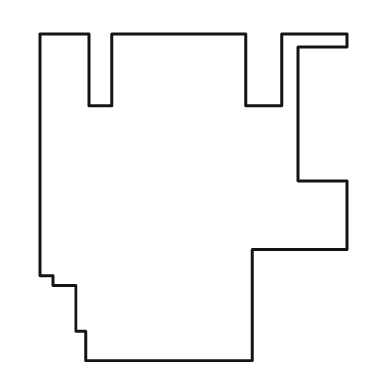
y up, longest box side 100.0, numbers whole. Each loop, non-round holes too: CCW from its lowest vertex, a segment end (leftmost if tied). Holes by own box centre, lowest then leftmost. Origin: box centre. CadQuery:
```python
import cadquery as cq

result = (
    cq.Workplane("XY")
    .moveTo(-33.0, -50.0)
    .lineTo(18.0, -50.0)
    .lineTo(18.0, -16.0)
    .lineTo(47.0, -16.0)
    .lineTo(47.0, 5.0)
    .lineTo(32.0, 5.0)
    .lineTo(32.0, 46.0)
    .lineTo(47.0, 46.0)
    .lineTo(47.0, 50.0)
    .lineTo(27.0, 50.0)
    .lineTo(27.0, 28.0)
    .lineTo(16.0, 28.0)
    .lineTo(16.0, 50.0)
    .lineTo(-25.0, 50.0)
    .lineTo(-25.0, 28.0)
    .lineTo(-32.0, 28.0)
    .lineTo(-32.0, 50.0)
    .lineTo(-47.0, 50.0)
    .lineTo(-47.0, -24.0)
    .lineTo(-43.0, -24.0)
    .lineTo(-43.0, -27.0)
    .lineTo(-36.0, -27.0)
    .lineTo(-36.0, -41.0)
    .lineTo(-33.0, -41.0)
    .close()
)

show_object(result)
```